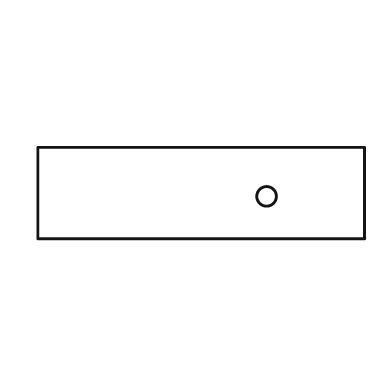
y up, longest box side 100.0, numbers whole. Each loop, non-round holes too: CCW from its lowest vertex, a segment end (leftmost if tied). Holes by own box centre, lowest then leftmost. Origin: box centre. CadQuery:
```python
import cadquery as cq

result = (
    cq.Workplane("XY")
    .moveTo(-50.0, -14.0)
    .lineTo(50.0, -14.0)
    .lineTo(50.0, 14.0)
    .lineTo(-50.0, 14.0)
    .close()
    .moveTo(20.0, -1.0)
    .circle(3.0)
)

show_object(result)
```